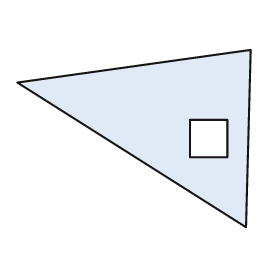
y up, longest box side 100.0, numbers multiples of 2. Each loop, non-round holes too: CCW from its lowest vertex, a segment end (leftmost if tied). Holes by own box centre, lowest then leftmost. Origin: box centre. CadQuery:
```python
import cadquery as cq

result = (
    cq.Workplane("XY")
    .moveTo(48.0, -38.0)
    .lineTo(50.0, 38.0)
    .lineTo(-50.0, 24.0)
    .close()
    .moveTo(24.0, -8.0)
    .lineTo(40.0, -8.0)
    .lineTo(40.0, 8.0)
    .lineTo(24.0, 8.0)
    .close()
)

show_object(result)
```